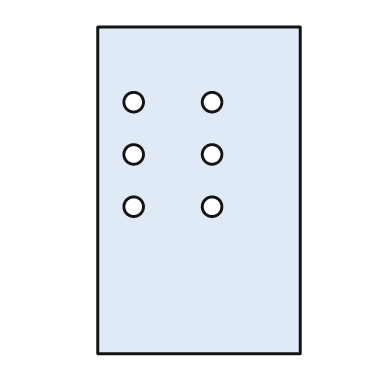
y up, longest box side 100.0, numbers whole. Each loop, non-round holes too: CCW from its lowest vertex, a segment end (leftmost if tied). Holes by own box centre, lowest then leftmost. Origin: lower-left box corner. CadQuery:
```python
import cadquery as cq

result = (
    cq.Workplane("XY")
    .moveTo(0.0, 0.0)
    .lineTo(62.0, 0.0)
    .lineTo(62.0, 100.0)
    .lineTo(0.0, 100.0)
    .close()
    .moveTo(11.0, 45.0)
    .circle(3.0)
    .moveTo(35.0, 45.0)
    .circle(3.0)
    .moveTo(11.0, 61.0)
    .circle(3.0)
    .moveTo(35.0, 61.0)
    .circle(3.0)
    .moveTo(11.0, 77.0)
    .circle(3.0)
    .moveTo(35.0, 77.0)
    .circle(3.0)
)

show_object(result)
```